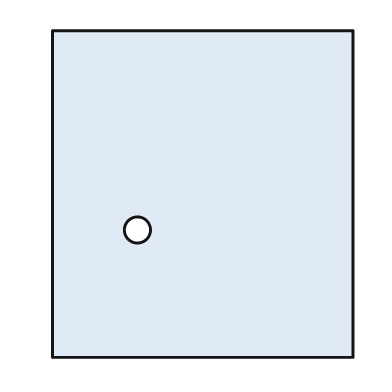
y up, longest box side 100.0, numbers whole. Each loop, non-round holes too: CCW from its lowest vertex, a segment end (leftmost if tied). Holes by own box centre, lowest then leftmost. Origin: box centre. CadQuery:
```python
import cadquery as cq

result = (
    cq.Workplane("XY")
    .moveTo(-46.0, -50.0)
    .lineTo(46.0, -50.0)
    .lineTo(46.0, 50.0)
    .lineTo(-46.0, 50.0)
    .close()
    .moveTo(-20.0, -11.0)
    .circle(4.0)
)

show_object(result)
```